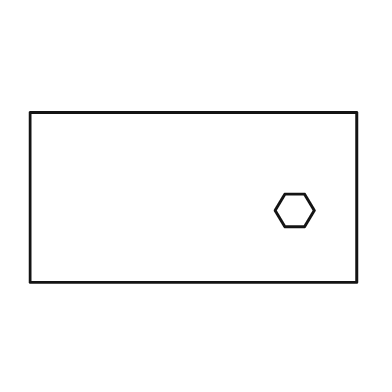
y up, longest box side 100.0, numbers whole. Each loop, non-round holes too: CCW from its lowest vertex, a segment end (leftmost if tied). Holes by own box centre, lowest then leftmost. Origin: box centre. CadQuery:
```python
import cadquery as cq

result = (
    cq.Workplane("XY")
    .moveTo(-50.0, -26.0)
    .lineTo(50.0, -26.0)
    .lineTo(50.0, 26.0)
    .lineTo(-50.0, 26.0)
    .close()
    .moveTo(28.0, -9.0)
    .lineTo(34.0, -9.0)
    .lineTo(37.0, -4.0)
    .lineTo(34.0, 1.0)
    .lineTo(28.0, 1.0)
    .lineTo(25.0, -4.0)
    .close()
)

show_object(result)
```